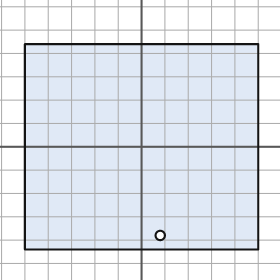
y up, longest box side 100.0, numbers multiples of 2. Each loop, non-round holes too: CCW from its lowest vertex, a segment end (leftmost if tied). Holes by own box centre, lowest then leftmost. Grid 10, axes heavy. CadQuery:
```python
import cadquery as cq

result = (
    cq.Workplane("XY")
    .moveTo(-50.0, -44.0)
    .lineTo(50.0, -44.0)
    .lineTo(50.0, 44.0)
    .lineTo(-50.0, 44.0)
    .close()
    .moveTo(8.0, -38.0)
    .circle(2.0)
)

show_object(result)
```